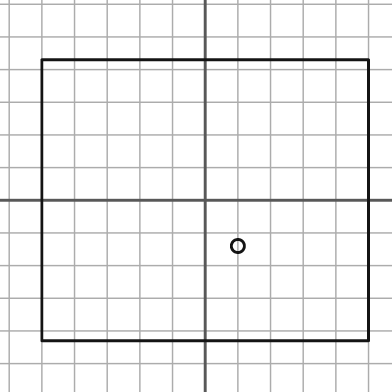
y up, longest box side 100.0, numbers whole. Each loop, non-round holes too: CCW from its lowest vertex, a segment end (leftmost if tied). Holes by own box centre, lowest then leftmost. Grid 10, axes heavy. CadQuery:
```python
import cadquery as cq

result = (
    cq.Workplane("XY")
    .moveTo(-50.0, -43.0)
    .lineTo(50.0, -43.0)
    .lineTo(50.0, 43.0)
    .lineTo(-50.0, 43.0)
    .close()
    .moveTo(10.0, -14.0)
    .circle(2.0)
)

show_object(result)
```